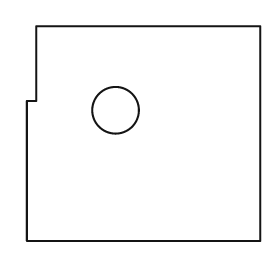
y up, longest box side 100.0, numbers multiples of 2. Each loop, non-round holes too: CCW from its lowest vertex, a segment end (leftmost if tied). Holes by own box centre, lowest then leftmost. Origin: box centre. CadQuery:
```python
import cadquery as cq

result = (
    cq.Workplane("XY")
    .moveTo(-50.0, -46.0)
    .lineTo(50.0, -46.0)
    .lineTo(50.0, 46.0)
    .lineTo(-46.0, 46.0)
    .lineTo(-46.0, 14.0)
    .lineTo(-50.0, 14.0)
    .close()
    .moveTo(-12.0, 10.0)
    .circle(10.0)
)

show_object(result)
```